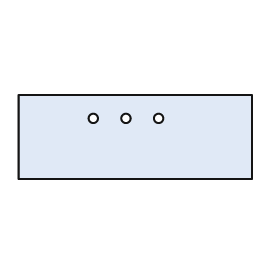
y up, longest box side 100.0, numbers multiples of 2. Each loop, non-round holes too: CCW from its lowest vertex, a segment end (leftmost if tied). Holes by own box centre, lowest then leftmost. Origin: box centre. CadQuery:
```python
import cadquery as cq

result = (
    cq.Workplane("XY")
    .moveTo(-50.0, -18.0)
    .lineTo(50.0, -18.0)
    .lineTo(50.0, 18.0)
    .lineTo(-50.0, 18.0)
    .close()
    .moveTo(-18.0, 8.0)
    .circle(2.0)
    .moveTo(-4.0, 8.0)
    .circle(2.0)
    .moveTo(10.0, 8.0)
    .circle(2.0)
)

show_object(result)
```